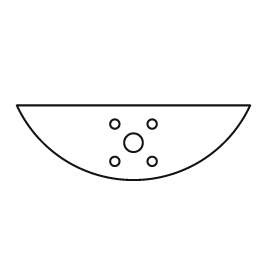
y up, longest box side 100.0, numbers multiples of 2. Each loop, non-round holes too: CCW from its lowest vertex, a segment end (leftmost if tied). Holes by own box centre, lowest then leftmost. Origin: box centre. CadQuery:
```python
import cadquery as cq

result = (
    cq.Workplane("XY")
    .moveTo(-50.0, 16.0)
    .threePointArc((0.0, -16.0), (50.0, 16.0))
    .close()
    .moveTo(-8.0, -8.0)
    .circle(2.0)
    .moveTo(8.0, -8.0)
    .circle(2.0)
    .moveTo(0.0, 0.0)
    .circle(4.0)
    .moveTo(-8.0, 8.0)
    .circle(2.0)
    .moveTo(8.0, 8.0)
    .circle(2.0)
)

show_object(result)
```